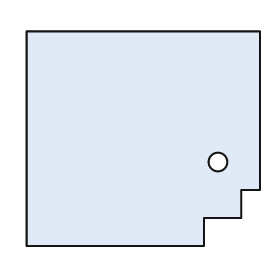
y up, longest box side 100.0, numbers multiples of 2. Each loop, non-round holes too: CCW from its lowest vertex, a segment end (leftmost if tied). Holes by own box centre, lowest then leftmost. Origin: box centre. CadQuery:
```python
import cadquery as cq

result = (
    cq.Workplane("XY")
    .moveTo(-50.0, -46.0)
    .lineTo(26.0, -46.0)
    .lineTo(26.0, -34.0)
    .lineTo(42.0, -34.0)
    .lineTo(42.0, -22.0)
    .lineTo(50.0, -22.0)
    .lineTo(50.0, 46.0)
    .lineTo(-50.0, 46.0)
    .close()
    .moveTo(32.0, -10.0)
    .circle(4.0)
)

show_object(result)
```